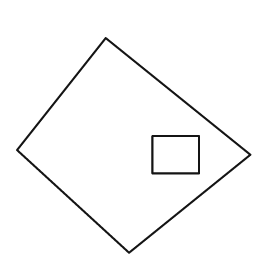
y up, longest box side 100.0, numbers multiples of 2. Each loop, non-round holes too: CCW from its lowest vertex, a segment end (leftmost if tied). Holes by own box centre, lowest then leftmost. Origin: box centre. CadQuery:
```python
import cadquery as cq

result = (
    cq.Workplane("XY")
    .moveTo(-2.0, -46.0)
    .lineTo(50.0, -4.0)
    .lineTo(-12.0, 46.0)
    .lineTo(-50.0, -2.0)
    .close()
    .moveTo(8.0, -12.0)
    .lineTo(28.0, -12.0)
    .lineTo(28.0, 4.0)
    .lineTo(8.0, 4.0)
    .close()
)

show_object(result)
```